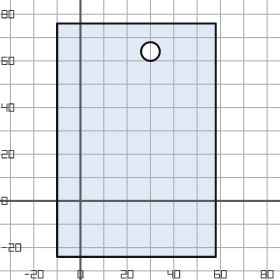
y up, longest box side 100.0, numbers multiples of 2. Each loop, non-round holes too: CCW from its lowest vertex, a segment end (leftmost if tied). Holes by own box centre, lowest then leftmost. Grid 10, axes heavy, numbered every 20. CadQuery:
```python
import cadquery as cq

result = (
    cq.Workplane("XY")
    .moveTo(-10.0, -24.0)
    .lineTo(58.0, -24.0)
    .lineTo(58.0, 76.0)
    .lineTo(-10.0, 76.0)
    .close()
    .moveTo(30.0, 64.0)
    .circle(4.0)
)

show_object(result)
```